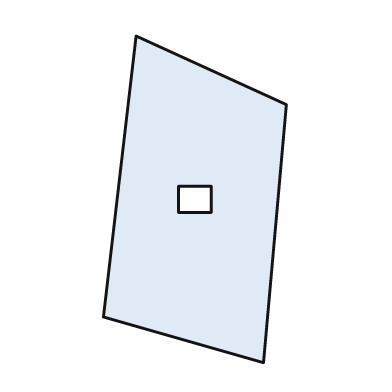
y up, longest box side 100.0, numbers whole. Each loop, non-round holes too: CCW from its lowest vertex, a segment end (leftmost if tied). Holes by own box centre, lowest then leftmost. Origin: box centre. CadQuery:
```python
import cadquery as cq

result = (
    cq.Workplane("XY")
    .moveTo(21.0, -50.0)
    .lineTo(28.0, 29.0)
    .lineTo(-18.0, 50.0)
    .lineTo(-28.0, -36.0)
    .close()
    .moveTo(-5.0, -4.0)
    .lineTo(5.0, -4.0)
    .lineTo(5.0, 4.0)
    .lineTo(-5.0, 4.0)
    .close()
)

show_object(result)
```